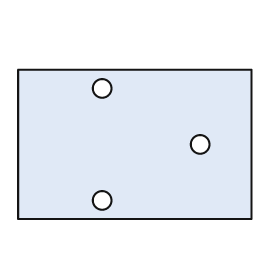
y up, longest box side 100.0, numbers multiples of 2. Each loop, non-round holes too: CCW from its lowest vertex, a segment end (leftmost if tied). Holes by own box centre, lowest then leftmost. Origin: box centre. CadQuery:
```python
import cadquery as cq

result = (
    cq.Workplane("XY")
    .moveTo(-50.0, -32.0)
    .lineTo(50.0, -32.0)
    .lineTo(50.0, 32.0)
    .lineTo(-50.0, 32.0)
    .close()
    .moveTo(-14.0, -24.0)
    .circle(4.0)
    .moveTo(28.0, 0.0)
    .circle(4.0)
    .moveTo(-14.0, 24.0)
    .circle(4.0)
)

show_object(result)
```